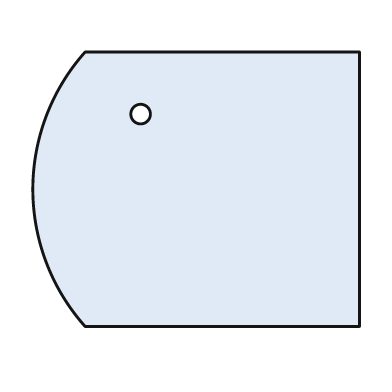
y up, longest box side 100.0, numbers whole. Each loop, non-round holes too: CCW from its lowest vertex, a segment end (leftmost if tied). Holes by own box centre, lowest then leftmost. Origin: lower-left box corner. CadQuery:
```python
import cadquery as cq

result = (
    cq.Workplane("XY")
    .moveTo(16.0, 0.0)
    .lineTo(100.0, 0.0)
    .lineTo(100.0, 84.0)
    .lineTo(16.0, 84.0)
    .threePointArc((0.0, 42.0), (16.0, 0.0))
    .close()
    .moveTo(33.0, 65.0)
    .circle(3.0)
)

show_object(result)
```